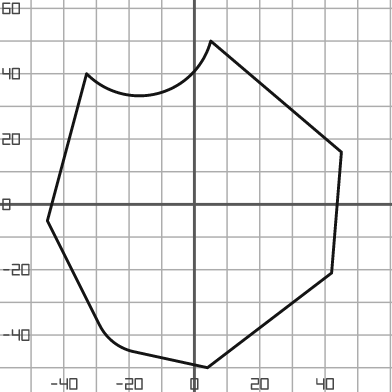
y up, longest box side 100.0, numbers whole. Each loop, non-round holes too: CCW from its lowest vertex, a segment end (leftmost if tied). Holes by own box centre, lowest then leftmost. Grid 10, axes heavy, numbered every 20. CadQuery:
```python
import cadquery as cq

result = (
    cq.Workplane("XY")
    .moveTo(4.0, -50.0)
    .lineTo(42.0, -21.0)
    .lineTo(45.0, 16.0)
    .lineTo(5.0, 50.0)
    .threePointArc((-11.0, 34.0), (-33.0, 40.0))
    .lineTo(-45.0, -5.0)
    .lineTo(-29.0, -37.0)
    .threePointArc((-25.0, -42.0), (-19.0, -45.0))
    .close()
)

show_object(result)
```